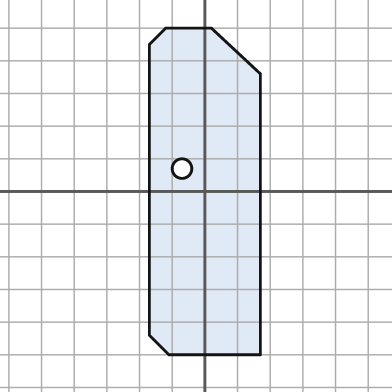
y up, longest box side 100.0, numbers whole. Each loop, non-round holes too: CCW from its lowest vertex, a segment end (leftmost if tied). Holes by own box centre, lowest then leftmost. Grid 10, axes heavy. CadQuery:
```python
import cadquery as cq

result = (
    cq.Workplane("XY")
    .moveTo(-11.0, -50.0)
    .lineTo(17.0, -50.0)
    .lineTo(17.0, 36.0)
    .lineTo(2.0, 50.0)
    .lineTo(-12.0, 50.0)
    .lineTo(-17.0, 45.0)
    .lineTo(-17.0, -44.0)
    .close()
    .moveTo(-7.0, 7.0)
    .circle(3.0)
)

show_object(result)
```